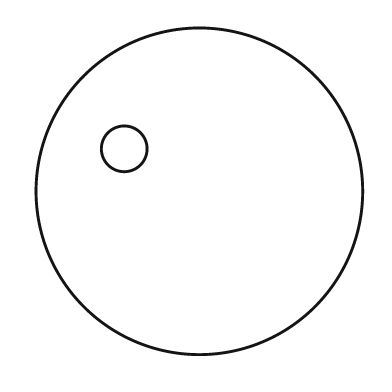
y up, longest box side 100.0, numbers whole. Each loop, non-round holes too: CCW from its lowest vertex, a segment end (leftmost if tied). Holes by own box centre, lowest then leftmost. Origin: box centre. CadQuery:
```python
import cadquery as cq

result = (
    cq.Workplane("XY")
    .moveTo(0.0, 0.0)
    .circle(50.0)
    .moveTo(-23.0, 13.0)
    .circle(7.0)
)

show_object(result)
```